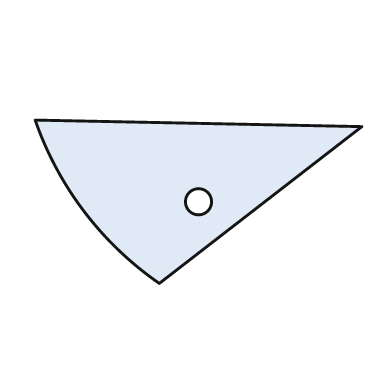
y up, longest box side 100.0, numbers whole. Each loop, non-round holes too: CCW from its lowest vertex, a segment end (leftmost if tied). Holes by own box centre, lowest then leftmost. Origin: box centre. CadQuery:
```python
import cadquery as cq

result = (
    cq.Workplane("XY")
    .moveTo(-12.0, -25.0)
    .lineTo(50.0, 23.0)
    .lineTo(-50.0, 25.0)
    .threePointArc((-35.0, -3.0), (-12.0, -25.0))
    .close()
    .moveTo(0.0, 0.0)
    .circle(4.0)
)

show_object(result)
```